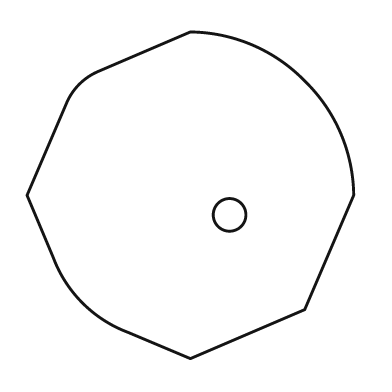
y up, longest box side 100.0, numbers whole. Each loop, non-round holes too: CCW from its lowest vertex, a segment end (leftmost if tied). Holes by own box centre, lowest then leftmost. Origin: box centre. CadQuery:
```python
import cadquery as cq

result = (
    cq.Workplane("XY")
    .moveTo(0.0, -50.0)
    .lineTo(35.0, -35.0)
    .lineTo(50.0, 0.0)
    .threePointArc((46.0, 19.0), (35.0, 35.0))
    .threePointArc((19.0, 46.0), (0.0, 50.0))
    .lineTo(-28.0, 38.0)
    .threePointArc((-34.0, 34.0), (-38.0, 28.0))
    .lineTo(-50.0, 0.0)
    .lineTo(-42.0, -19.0)
    .threePointArc((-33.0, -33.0), (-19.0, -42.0))
    .close()
    .moveTo(12.0, -6.0)
    .circle(5.0)
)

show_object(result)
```